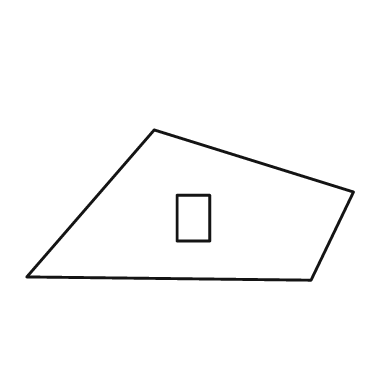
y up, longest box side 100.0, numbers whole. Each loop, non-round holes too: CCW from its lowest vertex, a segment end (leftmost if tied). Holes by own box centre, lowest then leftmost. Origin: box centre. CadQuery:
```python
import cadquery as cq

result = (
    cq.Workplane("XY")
    .moveTo(37.0, -23.0)
    .lineTo(50.0, 4.0)
    .lineTo(-11.0, 23.0)
    .lineTo(-50.0, -22.0)
    .close()
    .moveTo(-4.0, -11.0)
    .lineTo(6.0, -11.0)
    .lineTo(6.0, 3.0)
    .lineTo(-4.0, 3.0)
    .close()
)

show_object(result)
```